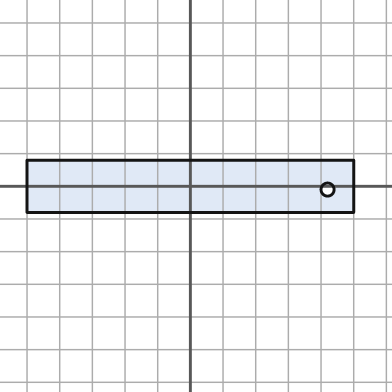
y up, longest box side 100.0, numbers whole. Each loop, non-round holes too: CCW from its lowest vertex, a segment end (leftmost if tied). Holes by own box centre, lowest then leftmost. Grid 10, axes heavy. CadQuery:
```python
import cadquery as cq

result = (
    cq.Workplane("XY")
    .moveTo(-50.0, -8.0)
    .lineTo(50.0, -8.0)
    .lineTo(50.0, 8.0)
    .lineTo(-50.0, 8.0)
    .close()
    .moveTo(42.0, -1.0)
    .circle(2.0)
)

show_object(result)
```